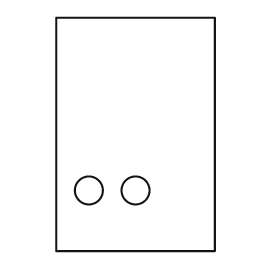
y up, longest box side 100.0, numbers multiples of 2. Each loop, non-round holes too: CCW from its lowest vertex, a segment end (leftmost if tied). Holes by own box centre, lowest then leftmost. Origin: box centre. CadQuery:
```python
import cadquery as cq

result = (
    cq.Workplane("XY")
    .moveTo(-34.0, -50.0)
    .lineTo(34.0, -50.0)
    .lineTo(34.0, 50.0)
    .lineTo(-34.0, 50.0)
    .close()
    .moveTo(-20.0, -24.0)
    .circle(6.0)
    .moveTo(0.0, -24.0)
    .circle(6.0)
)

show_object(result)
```